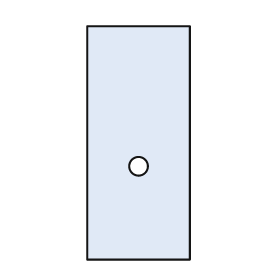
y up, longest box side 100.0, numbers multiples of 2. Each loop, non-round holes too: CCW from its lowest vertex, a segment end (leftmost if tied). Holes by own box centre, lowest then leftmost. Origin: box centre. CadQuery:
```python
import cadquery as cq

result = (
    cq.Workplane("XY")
    .moveTo(-22.0, -50.0)
    .lineTo(22.0, -50.0)
    .lineTo(22.0, 50.0)
    .lineTo(-22.0, 50.0)
    .close()
    .moveTo(0.0, -10.0)
    .circle(4.0)
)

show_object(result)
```